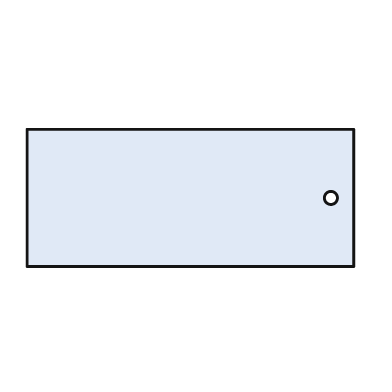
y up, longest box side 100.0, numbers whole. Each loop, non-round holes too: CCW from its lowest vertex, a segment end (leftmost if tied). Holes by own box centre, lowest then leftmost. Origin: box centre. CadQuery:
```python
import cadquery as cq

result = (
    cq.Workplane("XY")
    .moveTo(-50.0, -21.0)
    .lineTo(50.0, -21.0)
    .lineTo(50.0, 21.0)
    .lineTo(-50.0, 21.0)
    .close()
    .moveTo(43.0, 0.0)
    .circle(2.0)
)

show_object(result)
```